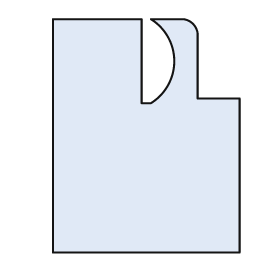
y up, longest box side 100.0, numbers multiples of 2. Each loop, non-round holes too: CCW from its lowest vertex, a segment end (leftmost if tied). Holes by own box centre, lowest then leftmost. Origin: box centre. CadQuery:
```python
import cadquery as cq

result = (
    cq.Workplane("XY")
    .moveTo(-40.0, -50.0)
    .lineTo(40.0, -50.0)
    .lineTo(40.0, 16.0)
    .lineTo(22.0, 16.0)
    .lineTo(22.0, 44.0)
    .threePointArc((20.0, 48.0), (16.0, 50.0))
    .lineTo(2.0, 50.0)
    .threePointArc((12.0, 32.0), (2.0, 14.0))
    .lineTo(-2.0, 14.0)
    .lineTo(-2.0, 50.0)
    .lineTo(-40.0, 50.0)
    .close()
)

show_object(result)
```